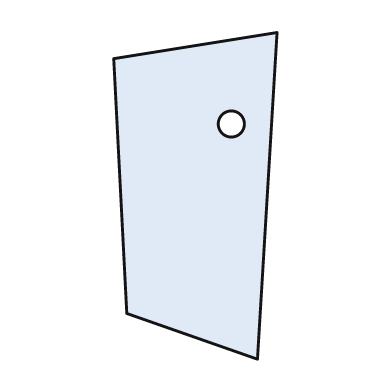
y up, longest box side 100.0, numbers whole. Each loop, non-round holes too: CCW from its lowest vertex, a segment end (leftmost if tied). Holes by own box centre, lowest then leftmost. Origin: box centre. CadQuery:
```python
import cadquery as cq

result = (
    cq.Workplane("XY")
    .moveTo(19.0, -50.0)
    .lineTo(25.0, 50.0)
    .lineTo(-25.0, 42.0)
    .lineTo(-21.0, -36.0)
    .close()
    .moveTo(11.0, 22.0)
    .circle(4.0)
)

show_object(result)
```